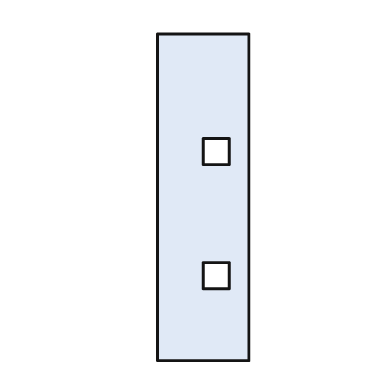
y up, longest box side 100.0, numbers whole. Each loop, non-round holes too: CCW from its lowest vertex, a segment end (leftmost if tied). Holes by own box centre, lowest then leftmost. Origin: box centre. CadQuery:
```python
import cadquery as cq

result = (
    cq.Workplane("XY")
    .moveTo(-14.0, -50.0)
    .lineTo(14.0, -50.0)
    .lineTo(14.0, 50.0)
    .lineTo(-14.0, 50.0)
    .close()
    .moveTo(0.0, -28.0)
    .lineTo(8.0, -28.0)
    .lineTo(8.0, -20.0)
    .lineTo(0.0, -20.0)
    .close()
    .moveTo(0.0, 10.0)
    .lineTo(8.0, 10.0)
    .lineTo(8.0, 18.0)
    .lineTo(0.0, 18.0)
    .close()
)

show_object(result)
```